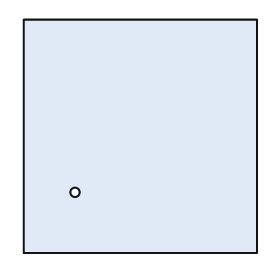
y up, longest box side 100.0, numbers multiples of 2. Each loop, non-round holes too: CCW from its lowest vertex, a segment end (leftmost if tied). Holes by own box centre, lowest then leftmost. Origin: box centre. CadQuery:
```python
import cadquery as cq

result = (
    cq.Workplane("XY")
    .moveTo(-50.0, -50.0)
    .lineTo(50.0, -50.0)
    .lineTo(50.0, 50.0)
    .lineTo(-50.0, 50.0)
    .close()
    .moveTo(-28.0, -24.0)
    .circle(2.0)
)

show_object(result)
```